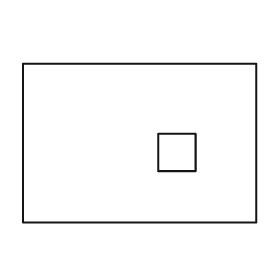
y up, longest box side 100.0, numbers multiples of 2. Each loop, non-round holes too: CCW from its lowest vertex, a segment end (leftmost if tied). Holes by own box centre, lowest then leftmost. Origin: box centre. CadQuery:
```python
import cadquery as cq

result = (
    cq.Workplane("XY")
    .moveTo(-50.0, -34.0)
    .lineTo(50.0, -34.0)
    .lineTo(50.0, 34.0)
    .lineTo(-50.0, 34.0)
    .close()
    .moveTo(8.0, -12.0)
    .lineTo(24.0, -12.0)
    .lineTo(24.0, 4.0)
    .lineTo(8.0, 4.0)
    .close()
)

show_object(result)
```